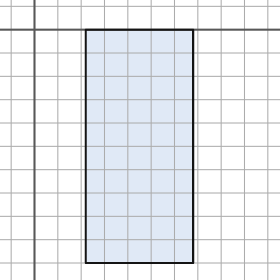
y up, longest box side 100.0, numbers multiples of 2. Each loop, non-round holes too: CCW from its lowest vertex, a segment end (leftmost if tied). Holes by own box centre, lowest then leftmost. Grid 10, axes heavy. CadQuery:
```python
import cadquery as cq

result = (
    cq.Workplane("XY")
    .moveTo(22.0, -100.0)
    .lineTo(68.0, -100.0)
    .lineTo(68.0, 0.0)
    .lineTo(22.0, 0.0)
    .close()
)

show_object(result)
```